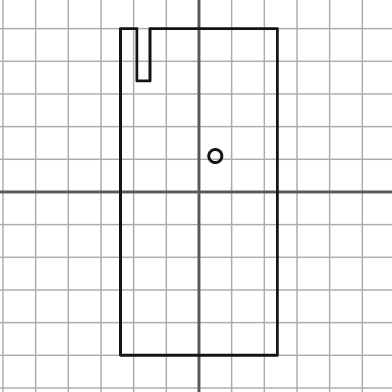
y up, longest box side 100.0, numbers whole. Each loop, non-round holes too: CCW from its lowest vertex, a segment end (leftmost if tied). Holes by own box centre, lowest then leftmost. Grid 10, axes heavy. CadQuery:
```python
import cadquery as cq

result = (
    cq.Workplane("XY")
    .moveTo(-24.0, -50.0)
    .lineTo(24.0, -50.0)
    .lineTo(24.0, 50.0)
    .lineTo(-15.0, 50.0)
    .lineTo(-15.0, 34.0)
    .lineTo(-19.0, 34.0)
    .lineTo(-19.0, 50.0)
    .lineTo(-24.0, 50.0)
    .close()
    .moveTo(5.0, 11.0)
    .circle(2.0)
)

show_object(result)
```